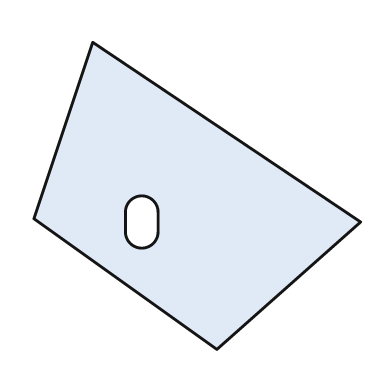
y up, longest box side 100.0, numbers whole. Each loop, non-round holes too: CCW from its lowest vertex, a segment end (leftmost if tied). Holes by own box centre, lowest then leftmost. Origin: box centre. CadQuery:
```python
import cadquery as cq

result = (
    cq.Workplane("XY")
    .moveTo(6.0, -47.0)
    .lineTo(50.0, -8.0)
    .lineTo(-32.0, 47.0)
    .lineTo(-50.0, -7.0)
    .close()
    .moveTo(-22.0, -11.0)
    .threePointArc((-17.0, -16.0), (-12.0, -11.0))
    .lineTo(-12.0, -5.0)
    .threePointArc((-17.0, 0.0), (-22.0, -5.0))
    .close()
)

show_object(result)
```